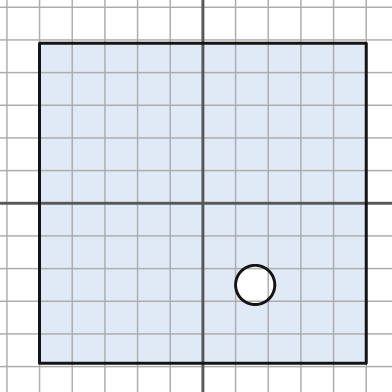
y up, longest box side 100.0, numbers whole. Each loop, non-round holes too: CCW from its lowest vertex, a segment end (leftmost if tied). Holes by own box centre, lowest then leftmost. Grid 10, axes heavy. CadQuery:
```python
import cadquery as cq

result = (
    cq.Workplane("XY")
    .moveTo(-50.0, -49.0)
    .lineTo(50.0, -49.0)
    .lineTo(50.0, 49.0)
    .lineTo(-50.0, 49.0)
    .close()
    .moveTo(16.0, -25.0)
    .circle(6.0)
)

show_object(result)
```